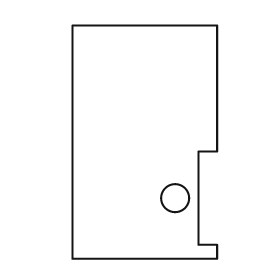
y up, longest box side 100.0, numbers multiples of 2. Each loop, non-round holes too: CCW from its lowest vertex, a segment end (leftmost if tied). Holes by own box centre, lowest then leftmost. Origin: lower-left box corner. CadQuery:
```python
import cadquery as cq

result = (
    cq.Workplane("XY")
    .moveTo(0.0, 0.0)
    .lineTo(62.0, 0.0)
    .lineTo(62.0, 6.0)
    .lineTo(54.0, 6.0)
    .lineTo(54.0, 46.0)
    .lineTo(62.0, 46.0)
    .lineTo(62.0, 100.0)
    .lineTo(0.0, 100.0)
    .close()
    .moveTo(44.0, 26.0)
    .circle(6.0)
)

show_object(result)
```